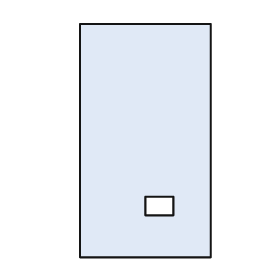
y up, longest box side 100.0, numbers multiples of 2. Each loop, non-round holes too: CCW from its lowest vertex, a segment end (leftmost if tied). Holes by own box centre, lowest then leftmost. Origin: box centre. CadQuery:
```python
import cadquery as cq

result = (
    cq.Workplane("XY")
    .moveTo(-28.0, -50.0)
    .lineTo(28.0, -50.0)
    .lineTo(28.0, 50.0)
    .lineTo(-28.0, 50.0)
    .close()
    .moveTo(0.0, -32.0)
    .lineTo(12.0, -32.0)
    .lineTo(12.0, -24.0)
    .lineTo(0.0, -24.0)
    .close()
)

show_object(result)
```